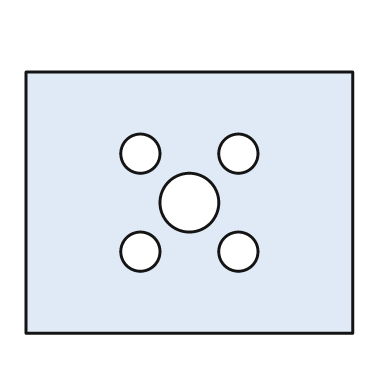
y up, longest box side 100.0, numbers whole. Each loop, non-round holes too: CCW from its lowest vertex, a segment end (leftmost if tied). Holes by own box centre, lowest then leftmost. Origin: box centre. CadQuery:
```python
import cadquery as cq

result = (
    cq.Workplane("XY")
    .moveTo(-50.0, -40.0)
    .lineTo(50.0, -40.0)
    .lineTo(50.0, 40.0)
    .lineTo(-50.0, 40.0)
    .close()
    .moveTo(-15.0, -15.0)
    .circle(6.0)
    .moveTo(15.0, -15.0)
    .circle(6.0)
    .moveTo(0.0, 0.0)
    .circle(9.0)
    .moveTo(-15.0, 15.0)
    .circle(6.0)
    .moveTo(15.0, 15.0)
    .circle(6.0)
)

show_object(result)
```